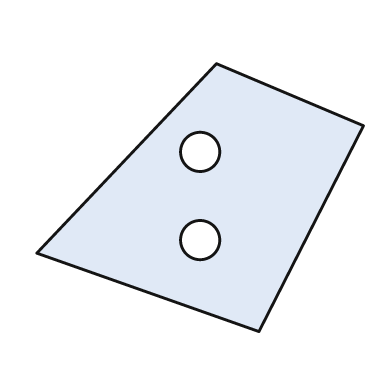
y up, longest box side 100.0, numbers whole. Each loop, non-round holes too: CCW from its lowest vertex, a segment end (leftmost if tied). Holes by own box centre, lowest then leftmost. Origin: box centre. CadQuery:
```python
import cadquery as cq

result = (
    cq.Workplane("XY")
    .moveTo(18.0, -41.0)
    .lineTo(50.0, 22.0)
    .lineTo(5.0, 41.0)
    .lineTo(-50.0, -17.0)
    .close()
    .moveTo(0.0, -13.0)
    .circle(6.0)
    .moveTo(0.0, 14.0)
    .circle(6.0)
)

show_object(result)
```